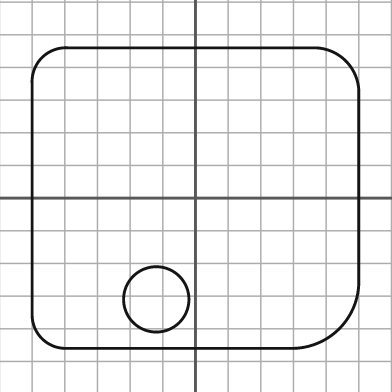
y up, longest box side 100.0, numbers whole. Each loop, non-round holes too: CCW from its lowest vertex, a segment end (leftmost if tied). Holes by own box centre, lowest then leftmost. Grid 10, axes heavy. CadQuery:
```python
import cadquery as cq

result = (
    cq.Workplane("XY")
    .moveTo(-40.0, -46.0)
    .lineTo(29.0, -46.0)
    .threePointArc((44.0, -40.0), (50.0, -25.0))
    .lineTo(50.0, 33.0)
    .threePointArc((46.0, 42.0), (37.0, 46.0))
    .lineTo(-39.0, 46.0)
    .threePointArc((-47.0, 43.0), (-50.0, 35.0))
    .lineTo(-50.0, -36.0)
    .threePointArc((-47.0, -43.0), (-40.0, -46.0))
    .close()
    .moveTo(-12.0, -31.0)
    .circle(10.0)
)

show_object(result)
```